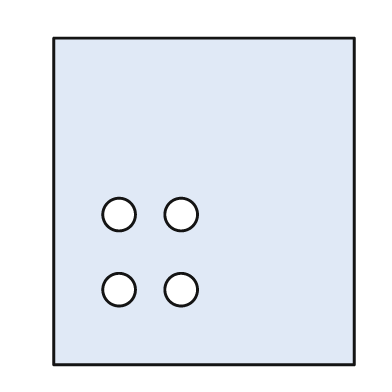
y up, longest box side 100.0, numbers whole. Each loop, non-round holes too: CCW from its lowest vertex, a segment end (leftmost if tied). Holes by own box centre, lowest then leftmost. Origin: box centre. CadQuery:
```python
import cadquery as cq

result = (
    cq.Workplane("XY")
    .moveTo(-46.0, -50.0)
    .lineTo(46.0, -50.0)
    .lineTo(46.0, 50.0)
    .lineTo(-46.0, 50.0)
    .close()
    .moveTo(-26.0, -27.0)
    .circle(5.0)
    .moveTo(-7.0, -27.0)
    .circle(5.0)
    .moveTo(-26.0, -4.0)
    .circle(5.0)
    .moveTo(-7.0, -4.0)
    .circle(5.0)
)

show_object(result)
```